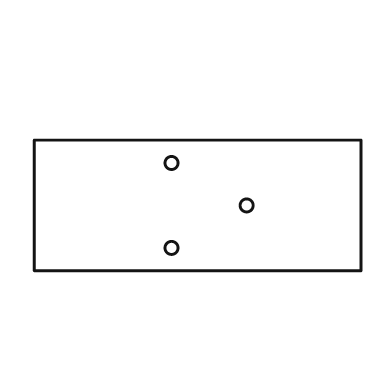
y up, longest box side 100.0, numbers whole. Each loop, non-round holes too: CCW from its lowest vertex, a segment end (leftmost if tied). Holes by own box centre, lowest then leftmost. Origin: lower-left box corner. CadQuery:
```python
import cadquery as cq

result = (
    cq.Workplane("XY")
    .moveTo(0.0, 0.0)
    .lineTo(100.0, 0.0)
    .lineTo(100.0, 40.0)
    .lineTo(0.0, 40.0)
    .close()
    .moveTo(42.0, 7.0)
    .circle(2.0)
    .moveTo(65.0, 20.0)
    .circle(2.0)
    .moveTo(42.0, 33.0)
    .circle(2.0)
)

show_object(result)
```